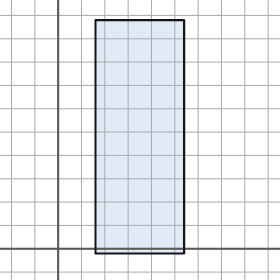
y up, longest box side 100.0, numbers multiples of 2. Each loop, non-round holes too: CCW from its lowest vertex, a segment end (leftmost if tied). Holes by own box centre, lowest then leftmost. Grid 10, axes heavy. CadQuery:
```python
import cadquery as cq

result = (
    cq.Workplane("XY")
    .moveTo(16.0, -2.0)
    .lineTo(54.0, -2.0)
    .lineTo(54.0, 98.0)
    .lineTo(16.0, 98.0)
    .close()
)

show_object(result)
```